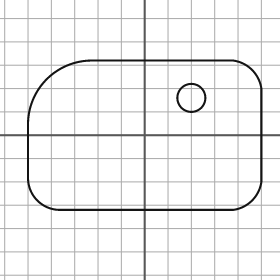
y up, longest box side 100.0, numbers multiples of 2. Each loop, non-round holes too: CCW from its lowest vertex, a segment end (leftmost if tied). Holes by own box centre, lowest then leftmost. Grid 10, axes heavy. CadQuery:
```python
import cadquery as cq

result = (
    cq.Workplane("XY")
    .moveTo(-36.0, -32.0)
    .lineTo(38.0, -32.0)
    .threePointArc((46.0, -28.0), (50.0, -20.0))
    .lineTo(50.0, 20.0)
    .threePointArc((46.0, 28.0), (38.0, 32.0))
    .lineTo(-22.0, 32.0)
    .threePointArc((-42.0, 24.0), (-50.0, 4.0))
    .lineTo(-50.0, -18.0)
    .threePointArc((-46.0, -28.0), (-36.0, -32.0))
    .close()
    .moveTo(20.0, 16.0)
    .circle(6.0)
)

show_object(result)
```